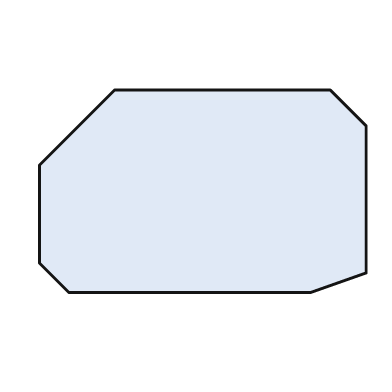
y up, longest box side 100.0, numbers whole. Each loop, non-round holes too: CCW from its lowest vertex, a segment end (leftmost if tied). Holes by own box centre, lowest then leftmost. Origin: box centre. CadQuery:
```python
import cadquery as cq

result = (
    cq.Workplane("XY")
    .moveTo(-41.0, -31.0)
    .lineTo(33.0, -31.0)
    .lineTo(50.0, -25.0)
    .lineTo(50.0, 20.0)
    .lineTo(39.0, 31.0)
    .lineTo(-27.0, 31.0)
    .lineTo(-50.0, 8.0)
    .lineTo(-50.0, -22.0)
    .close()
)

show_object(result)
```